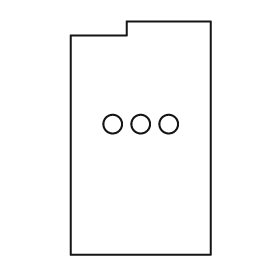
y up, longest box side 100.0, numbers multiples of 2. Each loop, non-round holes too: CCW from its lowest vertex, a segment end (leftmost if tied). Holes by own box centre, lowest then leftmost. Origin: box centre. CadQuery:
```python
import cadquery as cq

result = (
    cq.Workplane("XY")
    .moveTo(-30.0, -50.0)
    .lineTo(30.0, -50.0)
    .lineTo(30.0, 50.0)
    .lineTo(-6.0, 50.0)
    .lineTo(-6.0, 44.0)
    .lineTo(-30.0, 44.0)
    .close()
    .moveTo(-12.0, 6.0)
    .circle(4.0)
    .moveTo(0.0, 6.0)
    .circle(4.0)
    .moveTo(12.0, 6.0)
    .circle(4.0)
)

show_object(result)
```